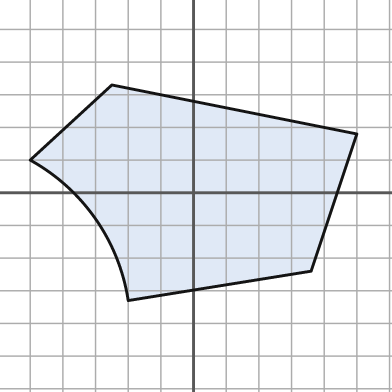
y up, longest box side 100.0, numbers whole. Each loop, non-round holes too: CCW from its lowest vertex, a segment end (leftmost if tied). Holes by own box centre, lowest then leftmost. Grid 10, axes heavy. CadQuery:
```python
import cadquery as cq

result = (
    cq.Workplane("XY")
    .moveTo(-20.0, -33.0)
    .lineTo(36.0, -24.0)
    .lineTo(50.0, 18.0)
    .lineTo(-25.0, 33.0)
    .lineTo(-50.0, 10.0)
    .threePointArc((-30.0, -8.0), (-20.0, -33.0))
    .close()
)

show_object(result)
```